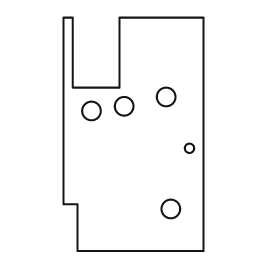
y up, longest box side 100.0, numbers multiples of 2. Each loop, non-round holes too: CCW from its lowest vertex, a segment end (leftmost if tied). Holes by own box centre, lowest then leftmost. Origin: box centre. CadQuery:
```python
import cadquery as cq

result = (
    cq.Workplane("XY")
    .moveTo(-24.0, -50.0)
    .lineTo(30.0, -50.0)
    .lineTo(30.0, 50.0)
    .lineTo(-6.0, 50.0)
    .lineTo(-6.0, 20.0)
    .lineTo(-26.0, 20.0)
    .lineTo(-26.0, 50.0)
    .lineTo(-30.0, 50.0)
    .lineTo(-30.0, -30.0)
    .lineTo(-24.0, -30.0)
    .close()
    .moveTo(16.0, -32.0)
    .circle(4.0)
    .moveTo(24.0, -6.0)
    .circle(2.0)
    .moveTo(-18.0, 10.0)
    .circle(4.0)
    .moveTo(-4.0, 12.0)
    .circle(4.0)
    .moveTo(14.0, 16.0)
    .circle(4.0)
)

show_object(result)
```